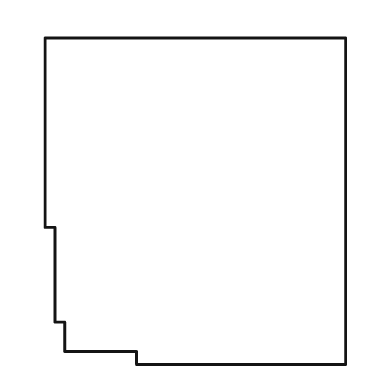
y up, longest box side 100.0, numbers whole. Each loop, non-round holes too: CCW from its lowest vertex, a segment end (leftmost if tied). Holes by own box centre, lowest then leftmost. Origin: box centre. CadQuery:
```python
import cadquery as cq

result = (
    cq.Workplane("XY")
    .moveTo(-18.0, -50.0)
    .lineTo(46.0, -50.0)
    .lineTo(46.0, 50.0)
    .lineTo(-46.0, 50.0)
    .lineTo(-46.0, -8.0)
    .lineTo(-43.0, -8.0)
    .lineTo(-43.0, -37.0)
    .lineTo(-40.0, -37.0)
    .lineTo(-40.0, -46.0)
    .lineTo(-18.0, -46.0)
    .close()
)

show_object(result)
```